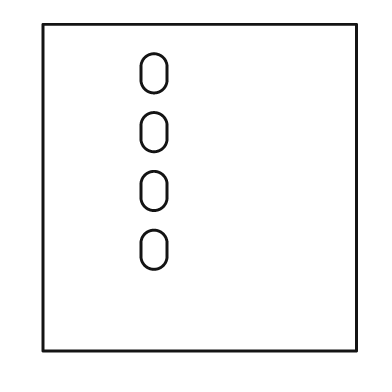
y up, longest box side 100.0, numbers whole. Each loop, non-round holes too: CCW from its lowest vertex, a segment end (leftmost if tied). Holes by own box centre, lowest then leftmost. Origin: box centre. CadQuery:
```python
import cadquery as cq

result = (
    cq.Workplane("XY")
    .moveTo(-48.0, -50.0)
    .lineTo(48.0, -50.0)
    .lineTo(48.0, 50.0)
    .lineTo(-48.0, 50.0)
    .close()
    .moveTo(-18.0, -21.0)
    .threePointArc((-14.0, -25.0), (-10.0, -21.0))
    .lineTo(-10.0, -17.0)
    .threePointArc((-14.0, -13.0), (-18.0, -17.0))
    .close()
    .moveTo(-18.0, -3.0)
    .threePointArc((-14.0, -7.0), (-10.0, -3.0))
    .lineTo(-10.0, 1.0)
    .threePointArc((-14.0, 5.0), (-18.0, 1.0))
    .close()
    .moveTo(-18.0, 15.0)
    .threePointArc((-14.0, 11.0), (-10.0, 15.0))
    .lineTo(-10.0, 19.0)
    .threePointArc((-14.0, 23.0), (-18.0, 19.0))
    .close()
    .moveTo(-18.0, 33.0)
    .threePointArc((-14.0, 29.0), (-10.0, 33.0))
    .lineTo(-10.0, 37.0)
    .threePointArc((-14.0, 41.0), (-18.0, 37.0))
    .close()
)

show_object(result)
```